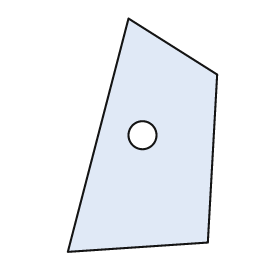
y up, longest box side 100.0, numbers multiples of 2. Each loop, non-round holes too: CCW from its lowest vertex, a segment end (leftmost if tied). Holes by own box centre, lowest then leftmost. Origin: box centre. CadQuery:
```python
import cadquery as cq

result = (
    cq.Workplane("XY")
    .moveTo(-32.0, -50.0)
    .lineTo(28.0, -46.0)
    .lineTo(32.0, 26.0)
    .lineTo(-6.0, 50.0)
    .close()
    .moveTo(0.0, 0.0)
    .circle(6.0)
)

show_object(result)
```